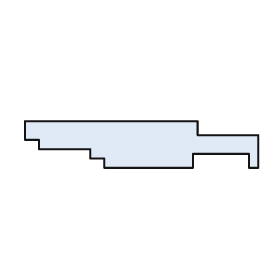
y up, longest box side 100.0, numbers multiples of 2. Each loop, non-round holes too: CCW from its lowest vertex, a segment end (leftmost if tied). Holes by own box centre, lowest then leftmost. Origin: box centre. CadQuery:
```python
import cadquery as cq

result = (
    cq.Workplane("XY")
    .moveTo(-16.0, -10.0)
    .lineTo(22.0, -10.0)
    .lineTo(22.0, -4.0)
    .lineTo(46.0, -4.0)
    .lineTo(46.0, -10.0)
    .lineTo(50.0, -10.0)
    .lineTo(50.0, 4.0)
    .lineTo(24.0, 4.0)
    .lineTo(24.0, 10.0)
    .lineTo(-50.0, 10.0)
    .lineTo(-50.0, 2.0)
    .lineTo(-44.0, 2.0)
    .lineTo(-44.0, -2.0)
    .lineTo(-22.0, -2.0)
    .lineTo(-22.0, -6.0)
    .lineTo(-16.0, -6.0)
    .close()
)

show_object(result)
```